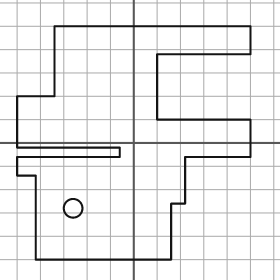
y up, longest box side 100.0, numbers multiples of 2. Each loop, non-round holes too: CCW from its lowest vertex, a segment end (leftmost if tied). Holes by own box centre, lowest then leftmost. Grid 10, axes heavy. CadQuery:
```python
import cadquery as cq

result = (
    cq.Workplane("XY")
    .moveTo(-42.0, -50.0)
    .lineTo(16.0, -50.0)
    .lineTo(16.0, -26.0)
    .lineTo(22.0, -26.0)
    .lineTo(22.0, -6.0)
    .lineTo(50.0, -6.0)
    .lineTo(50.0, 10.0)
    .lineTo(10.0, 10.0)
    .lineTo(10.0, 38.0)
    .lineTo(50.0, 38.0)
    .lineTo(50.0, 50.0)
    .lineTo(-34.0, 50.0)
    .lineTo(-34.0, 20.0)
    .lineTo(-50.0, 20.0)
    .lineTo(-50.0, -2.0)
    .lineTo(-6.0, -2.0)
    .lineTo(-6.0, -6.0)
    .lineTo(-50.0, -6.0)
    .lineTo(-50.0, -14.0)
    .lineTo(-42.0, -14.0)
    .close()
    .moveTo(-26.0, -28.0)
    .circle(4.0)
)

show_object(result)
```